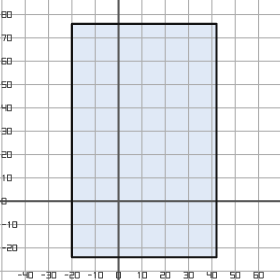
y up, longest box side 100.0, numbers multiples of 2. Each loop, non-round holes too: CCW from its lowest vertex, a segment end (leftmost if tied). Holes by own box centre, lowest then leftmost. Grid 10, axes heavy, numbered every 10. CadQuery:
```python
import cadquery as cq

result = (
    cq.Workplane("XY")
    .moveTo(-20.0, -24.0)
    .lineTo(42.0, -24.0)
    .lineTo(42.0, 76.0)
    .lineTo(-20.0, 76.0)
    .close()
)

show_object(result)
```